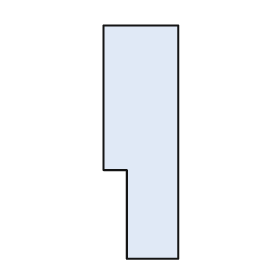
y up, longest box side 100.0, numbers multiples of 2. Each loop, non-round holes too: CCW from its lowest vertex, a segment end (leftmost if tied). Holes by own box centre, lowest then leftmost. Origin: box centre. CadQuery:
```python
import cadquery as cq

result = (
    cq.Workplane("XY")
    .moveTo(-6.0, -50.0)
    .lineTo(16.0, -50.0)
    .lineTo(16.0, 50.0)
    .lineTo(-16.0, 50.0)
    .lineTo(-16.0, -12.0)
    .lineTo(-6.0, -12.0)
    .close()
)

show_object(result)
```